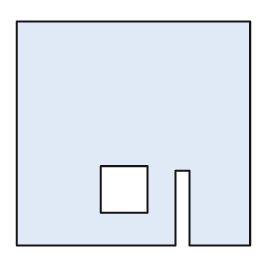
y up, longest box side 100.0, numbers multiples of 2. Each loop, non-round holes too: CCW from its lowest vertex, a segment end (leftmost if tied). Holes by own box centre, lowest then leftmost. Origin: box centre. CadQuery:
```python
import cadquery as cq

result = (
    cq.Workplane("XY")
    .moveTo(-50.0, -48.0)
    .lineTo(18.0, -48.0)
    .lineTo(18.0, -16.0)
    .lineTo(24.0, -16.0)
    .lineTo(24.0, -48.0)
    .lineTo(50.0, -48.0)
    .lineTo(50.0, 48.0)
    .lineTo(-50.0, 48.0)
    .close()
    .moveTo(-14.0, -34.0)
    .lineTo(6.0, -34.0)
    .lineTo(6.0, -14.0)
    .lineTo(-14.0, -14.0)
    .close()
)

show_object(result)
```